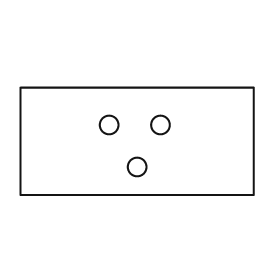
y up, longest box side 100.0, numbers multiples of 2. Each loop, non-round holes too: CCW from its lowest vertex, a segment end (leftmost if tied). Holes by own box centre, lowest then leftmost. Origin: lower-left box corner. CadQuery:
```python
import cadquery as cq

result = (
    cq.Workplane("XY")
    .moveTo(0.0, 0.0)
    .lineTo(100.0, 0.0)
    .lineTo(100.0, 46.0)
    .lineTo(0.0, 46.0)
    .close()
    .moveTo(50.0, 12.0)
    .circle(4.0)
    .moveTo(38.0, 30.0)
    .circle(4.0)
    .moveTo(60.0, 30.0)
    .circle(4.0)
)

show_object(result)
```